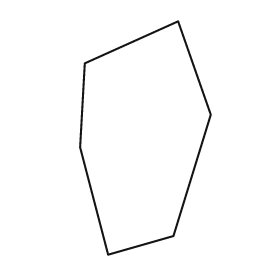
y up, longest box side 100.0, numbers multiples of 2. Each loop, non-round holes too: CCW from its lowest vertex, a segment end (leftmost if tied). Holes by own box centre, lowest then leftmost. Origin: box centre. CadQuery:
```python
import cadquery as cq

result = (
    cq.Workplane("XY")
    .moveTo(-16.0, -50.0)
    .lineTo(12.0, -42.0)
    .lineTo(28.0, 10.0)
    .lineTo(14.0, 50.0)
    .lineTo(-26.0, 32.0)
    .lineTo(-28.0, -4.0)
    .close()
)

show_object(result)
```